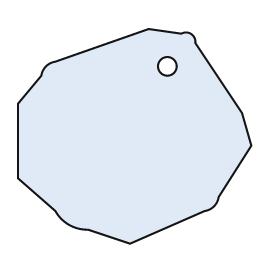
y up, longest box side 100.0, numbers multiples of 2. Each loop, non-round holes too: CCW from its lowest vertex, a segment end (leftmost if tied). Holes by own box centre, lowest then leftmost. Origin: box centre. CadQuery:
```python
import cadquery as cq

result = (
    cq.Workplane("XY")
    .moveTo(-2.0, -46.0)
    .lineTo(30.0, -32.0)
    .threePointArc((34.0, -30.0), (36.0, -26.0))
    .lineTo(50.0, -4.0)
    .lineTo(46.0, 10.0)
    .lineTo(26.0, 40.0)
    .threePointArc((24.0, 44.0), (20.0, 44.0))
    .lineTo(6.0, 46.0)
    .lineTo(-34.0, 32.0)
    .threePointArc((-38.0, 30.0), (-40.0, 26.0))
    .lineTo(-50.0, 14.0)
    .lineTo(-50.0, -18.0)
    .lineTo(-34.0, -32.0)
    .threePointArc((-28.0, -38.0), (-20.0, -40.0))
    .close()
    .moveTo(14.0, 30.0)
    .circle(4.0)
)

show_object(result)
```